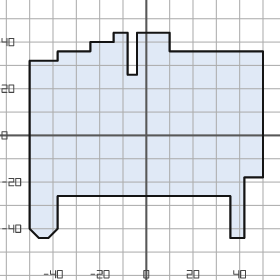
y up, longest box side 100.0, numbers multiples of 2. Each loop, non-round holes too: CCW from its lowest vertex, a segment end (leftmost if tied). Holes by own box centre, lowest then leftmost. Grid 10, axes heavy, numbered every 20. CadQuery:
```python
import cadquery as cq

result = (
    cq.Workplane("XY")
    .moveTo(-46.0, -44.0)
    .lineTo(-42.0, -44.0)
    .lineTo(-38.0, -40.0)
    .lineTo(-38.0, -26.0)
    .lineTo(36.0, -26.0)
    .lineTo(36.0, -44.0)
    .lineTo(42.0, -44.0)
    .lineTo(42.0, -18.0)
    .lineTo(50.0, -18.0)
    .lineTo(50.0, 36.0)
    .lineTo(10.0, 36.0)
    .lineTo(10.0, 44.0)
    .lineTo(-4.0, 44.0)
    .lineTo(-4.0, 26.0)
    .lineTo(-8.0, 26.0)
    .lineTo(-8.0, 44.0)
    .lineTo(-14.0, 44.0)
    .lineTo(-14.0, 40.0)
    .lineTo(-24.0, 40.0)
    .lineTo(-24.0, 36.0)
    .lineTo(-38.0, 36.0)
    .lineTo(-38.0, 32.0)
    .lineTo(-50.0, 32.0)
    .lineTo(-50.0, -40.0)
    .close()
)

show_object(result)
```